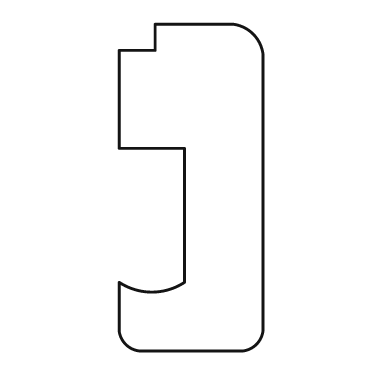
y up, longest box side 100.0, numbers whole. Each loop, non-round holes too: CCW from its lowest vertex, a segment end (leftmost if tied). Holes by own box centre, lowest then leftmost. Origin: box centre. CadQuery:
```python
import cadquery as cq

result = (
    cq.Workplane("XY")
    .moveTo(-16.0, -50.0)
    .lineTo(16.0, -50.0)
    .threePointArc((20.0, -48.0), (22.0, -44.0))
    .lineTo(22.0, 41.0)
    .threePointArc((19.0, 47.0), (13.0, 50.0))
    .lineTo(-11.0, 50.0)
    .lineTo(-11.0, 42.0)
    .lineTo(-22.0, 42.0)
    .lineTo(-22.0, 12.0)
    .lineTo(-2.0, 12.0)
    .lineTo(-2.0, -29.0)
    .threePointArc((-12.0, -32.0), (-22.0, -29.0))
    .lineTo(-22.0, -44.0)
    .threePointArc((-20.0, -48.0), (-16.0, -50.0))
    .close()
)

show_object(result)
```